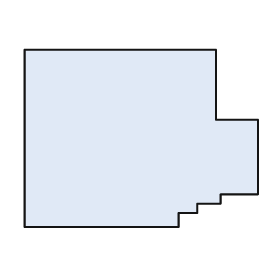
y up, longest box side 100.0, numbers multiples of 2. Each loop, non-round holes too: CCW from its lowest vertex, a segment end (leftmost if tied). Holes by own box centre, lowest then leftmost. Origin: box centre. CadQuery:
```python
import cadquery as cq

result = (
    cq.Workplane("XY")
    .moveTo(-50.0, -38.0)
    .lineTo(16.0, -38.0)
    .lineTo(16.0, -32.0)
    .lineTo(24.0, -32.0)
    .lineTo(24.0, -28.0)
    .lineTo(34.0, -28.0)
    .lineTo(34.0, -24.0)
    .lineTo(50.0, -24.0)
    .lineTo(50.0, 8.0)
    .lineTo(32.0, 8.0)
    .lineTo(32.0, 38.0)
    .lineTo(-50.0, 38.0)
    .close()
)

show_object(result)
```